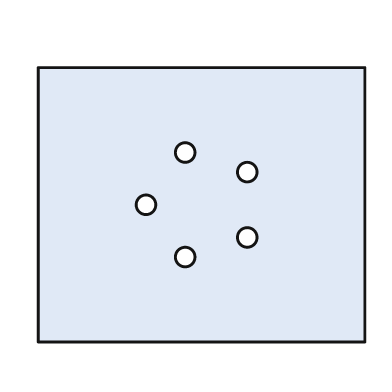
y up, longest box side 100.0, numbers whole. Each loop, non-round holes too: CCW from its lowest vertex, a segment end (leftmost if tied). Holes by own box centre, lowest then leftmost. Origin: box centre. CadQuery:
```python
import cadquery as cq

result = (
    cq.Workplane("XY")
    .moveTo(-50.0, -42.0)
    .lineTo(50.0, -42.0)
    .lineTo(50.0, 42.0)
    .lineTo(-50.0, 42.0)
    .close()
    .moveTo(-5.0, -16.0)
    .circle(3.0)
    .moveTo(14.0, -10.0)
    .circle(3.0)
    .moveTo(-17.0, 0.0)
    .circle(3.0)
    .moveTo(14.0, 10.0)
    .circle(3.0)
    .moveTo(-5.0, 16.0)
    .circle(3.0)
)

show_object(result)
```